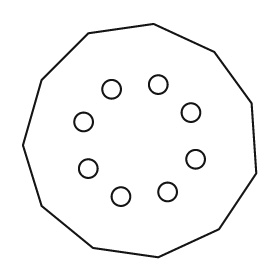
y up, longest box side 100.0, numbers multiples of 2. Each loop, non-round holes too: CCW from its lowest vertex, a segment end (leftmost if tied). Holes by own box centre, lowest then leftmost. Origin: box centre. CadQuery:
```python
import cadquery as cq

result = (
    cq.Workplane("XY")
    .moveTo(8.0, -50.0)
    .lineTo(34.0, -38.0)
    .lineTo(50.0, -14.0)
    .lineTo(48.0, 16.0)
    .lineTo(32.0, 38.0)
    .lineTo(6.0, 50.0)
    .lineTo(-22.0, 46.0)
    .lineTo(-42.0, 26.0)
    .lineTo(-50.0, -2.0)
    .lineTo(-42.0, -28.0)
    .lineTo(-20.0, -46.0)
    .close()
    .moveTo(-8.0, -24.0)
    .circle(4.0)
    .moveTo(12.0, -22.0)
    .circle(4.0)
    .moveTo(-22.0, -12.0)
    .circle(4.0)
    .moveTo(24.0, -8.0)
    .circle(4.0)
    .moveTo(-24.0, 8.0)
    .circle(4.0)
    .moveTo(22.0, 12.0)
    .circle(4.0)
    .moveTo(-12.0, 22.0)
    .circle(4.0)
    .moveTo(8.0, 24.0)
    .circle(4.0)
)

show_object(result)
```